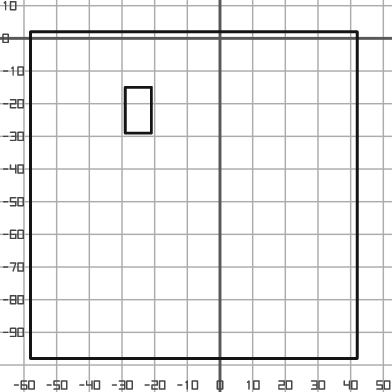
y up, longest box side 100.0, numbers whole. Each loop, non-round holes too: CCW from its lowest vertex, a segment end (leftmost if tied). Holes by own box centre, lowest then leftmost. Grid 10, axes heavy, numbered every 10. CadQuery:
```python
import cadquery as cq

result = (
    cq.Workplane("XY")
    .moveTo(-58.0, -98.0)
    .lineTo(42.0, -98.0)
    .lineTo(42.0, 2.0)
    .lineTo(-58.0, 2.0)
    .close()
    .moveTo(-29.0, -29.0)
    .lineTo(-21.0, -29.0)
    .lineTo(-21.0, -15.0)
    .lineTo(-29.0, -15.0)
    .close()
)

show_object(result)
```